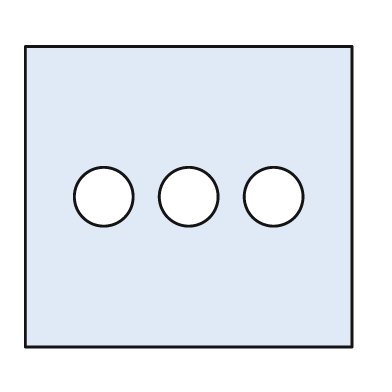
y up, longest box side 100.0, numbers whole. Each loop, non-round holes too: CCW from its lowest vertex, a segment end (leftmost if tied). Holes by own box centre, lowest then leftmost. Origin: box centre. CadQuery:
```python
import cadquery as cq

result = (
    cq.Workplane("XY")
    .moveTo(-50.0, -46.0)
    .lineTo(50.0, -46.0)
    .lineTo(50.0, 46.0)
    .lineTo(-50.0, 46.0)
    .close()
    .moveTo(-26.0, 0.0)
    .circle(9.0)
    .moveTo(0.0, 0.0)
    .circle(9.0)
    .moveTo(26.0, 0.0)
    .circle(9.0)
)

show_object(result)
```